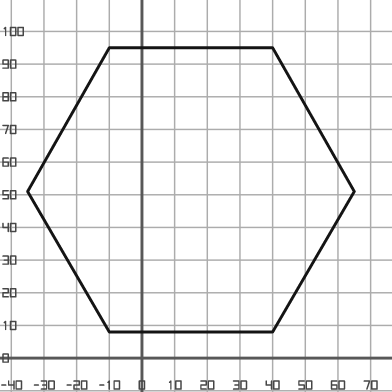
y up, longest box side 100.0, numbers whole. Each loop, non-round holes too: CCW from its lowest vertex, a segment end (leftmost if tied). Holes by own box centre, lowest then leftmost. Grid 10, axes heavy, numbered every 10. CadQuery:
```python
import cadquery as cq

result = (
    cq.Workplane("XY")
    .moveTo(-10.0, 8.0)
    .lineTo(40.0, 8.0)
    .lineTo(65.0, 51.0)
    .lineTo(40.0, 95.0)
    .lineTo(-10.0, 95.0)
    .lineTo(-35.0, 51.0)
    .close()
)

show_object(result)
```